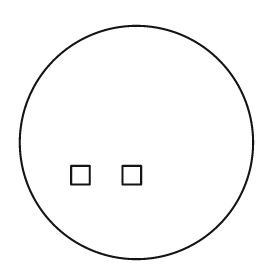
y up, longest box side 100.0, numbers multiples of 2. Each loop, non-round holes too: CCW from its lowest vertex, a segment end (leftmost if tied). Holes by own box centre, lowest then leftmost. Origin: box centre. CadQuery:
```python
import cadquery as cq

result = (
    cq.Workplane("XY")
    .moveTo(0.0, 0.0)
    .circle(50.0)
    .moveTo(-28.0, -18.0)
    .lineTo(-20.0, -18.0)
    .lineTo(-20.0, -10.0)
    .lineTo(-28.0, -10.0)
    .close()
    .moveTo(-6.0, -18.0)
    .lineTo(2.0, -18.0)
    .lineTo(2.0, -10.0)
    .lineTo(-6.0, -10.0)
    .close()
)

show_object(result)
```